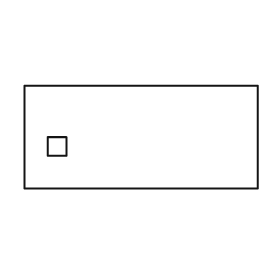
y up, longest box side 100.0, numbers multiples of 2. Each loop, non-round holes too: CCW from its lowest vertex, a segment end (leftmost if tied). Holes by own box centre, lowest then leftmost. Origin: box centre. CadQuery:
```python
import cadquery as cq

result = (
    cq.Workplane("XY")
    .moveTo(-50.0, -22.0)
    .lineTo(50.0, -22.0)
    .lineTo(50.0, 22.0)
    .lineTo(-50.0, 22.0)
    .close()
    .moveTo(-40.0, -8.0)
    .lineTo(-32.0, -8.0)
    .lineTo(-32.0, 0.0)
    .lineTo(-40.0, 0.0)
    .close()
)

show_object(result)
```